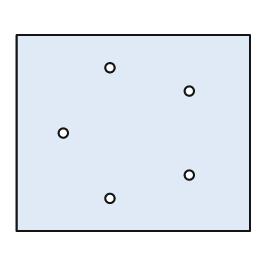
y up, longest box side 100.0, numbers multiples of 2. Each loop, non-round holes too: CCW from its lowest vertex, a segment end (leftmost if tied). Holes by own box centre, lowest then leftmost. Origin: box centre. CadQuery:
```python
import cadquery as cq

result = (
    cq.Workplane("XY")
    .moveTo(-50.0, -42.0)
    .lineTo(50.0, -42.0)
    .lineTo(50.0, 42.0)
    .lineTo(-50.0, 42.0)
    .close()
    .moveTo(-10.0, -28.0)
    .circle(2.0)
    .moveTo(24.0, -18.0)
    .circle(2.0)
    .moveTo(-30.0, 0.0)
    .circle(2.0)
    .moveTo(24.0, 18.0)
    .circle(2.0)
    .moveTo(-10.0, 28.0)
    .circle(2.0)
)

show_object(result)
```